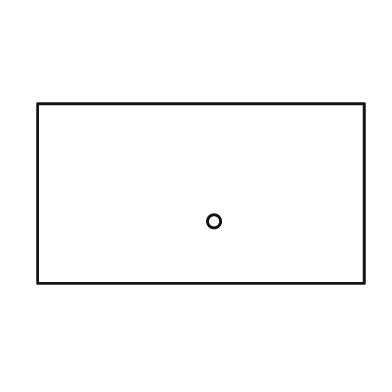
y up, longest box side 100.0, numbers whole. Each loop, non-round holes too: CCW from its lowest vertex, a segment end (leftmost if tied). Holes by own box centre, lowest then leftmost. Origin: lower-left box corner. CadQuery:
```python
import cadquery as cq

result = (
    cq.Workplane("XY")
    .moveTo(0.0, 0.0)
    .lineTo(100.0, 0.0)
    .lineTo(100.0, 55.0)
    .lineTo(0.0, 55.0)
    .close()
    .moveTo(54.0, 19.0)
    .circle(2.0)
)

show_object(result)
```